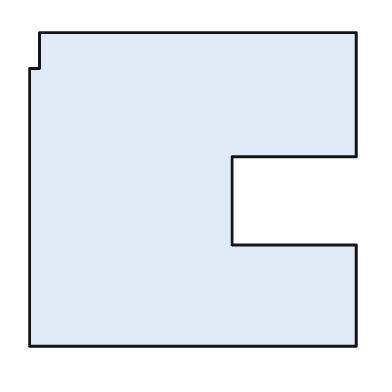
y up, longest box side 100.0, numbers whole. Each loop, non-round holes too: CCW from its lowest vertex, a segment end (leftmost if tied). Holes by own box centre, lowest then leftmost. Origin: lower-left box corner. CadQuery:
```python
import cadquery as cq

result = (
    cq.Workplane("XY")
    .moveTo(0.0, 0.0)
    .lineTo(100.0, 0.0)
    .lineTo(100.0, 31.0)
    .lineTo(62.0, 31.0)
    .lineTo(62.0, 58.0)
    .lineTo(100.0, 58.0)
    .lineTo(100.0, 96.0)
    .lineTo(3.0, 96.0)
    .lineTo(3.0, 85.0)
    .lineTo(0.0, 85.0)
    .close()
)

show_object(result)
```